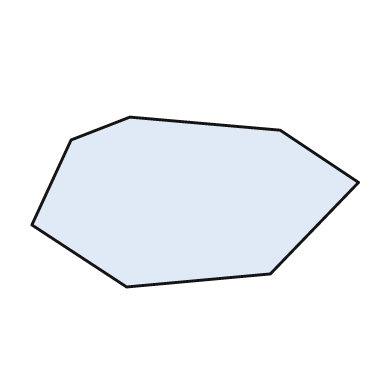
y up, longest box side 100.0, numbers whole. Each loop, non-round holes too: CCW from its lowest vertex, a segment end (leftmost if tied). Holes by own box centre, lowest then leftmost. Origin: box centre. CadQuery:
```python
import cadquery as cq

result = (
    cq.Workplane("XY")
    .moveTo(-21.0, -26.0)
    .lineTo(23.0, -22.0)
    .lineTo(50.0, 6.0)
    .lineTo(26.0, 22.0)
    .lineTo(-20.0, 26.0)
    .lineTo(-38.0, 19.0)
    .lineTo(-50.0, -7.0)
    .close()
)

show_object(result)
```